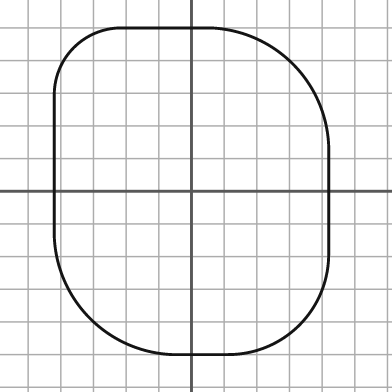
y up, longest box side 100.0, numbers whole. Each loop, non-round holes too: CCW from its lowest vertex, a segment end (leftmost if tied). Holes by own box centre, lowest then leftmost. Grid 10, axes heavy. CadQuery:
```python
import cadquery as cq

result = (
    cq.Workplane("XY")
    .moveTo(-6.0, -50.0)
    .lineTo(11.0, -50.0)
    .threePointArc((33.0, -41.0), (42.0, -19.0))
    .lineTo(42.0, 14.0)
    .threePointArc((31.0, 39.0), (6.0, 50.0))
    .lineTo(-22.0, 50.0)
    .threePointArc((-36.0, 44.0), (-42.0, 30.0))
    .lineTo(-42.0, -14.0)
    .threePointArc((-31.0, -39.0), (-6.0, -50.0))
    .close()
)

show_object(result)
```